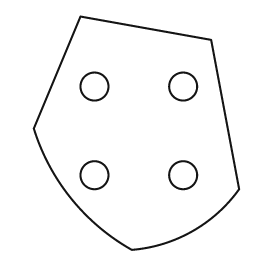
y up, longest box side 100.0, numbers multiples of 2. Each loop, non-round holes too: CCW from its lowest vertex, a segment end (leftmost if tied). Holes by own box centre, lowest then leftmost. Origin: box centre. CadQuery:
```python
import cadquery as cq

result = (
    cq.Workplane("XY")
    .moveTo(-2.0, -50.0)
    .threePointArc((24.0, -42.0), (44.0, -24.0))
    .lineTo(32.0, 40.0)
    .lineTo(-24.0, 50.0)
    .lineTo(-44.0, 2.0)
    .threePointArc((-28.0, -28.0), (-2.0, -50.0))
    .close()
    .moveTo(-18.0, -18.0)
    .circle(6.0)
    .moveTo(20.0, -18.0)
    .circle(6.0)
    .moveTo(-18.0, 20.0)
    .circle(6.0)
    .moveTo(20.0, 20.0)
    .circle(6.0)
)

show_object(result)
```